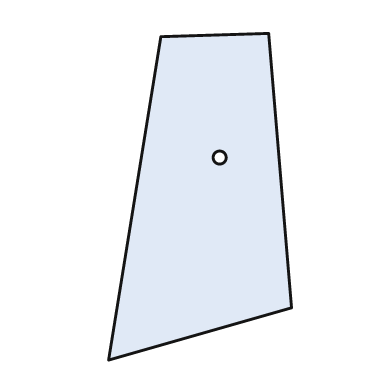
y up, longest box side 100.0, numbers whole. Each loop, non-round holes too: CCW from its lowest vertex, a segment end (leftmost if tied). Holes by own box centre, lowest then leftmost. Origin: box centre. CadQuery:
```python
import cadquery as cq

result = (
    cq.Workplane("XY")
    .moveTo(-28.0, -50.0)
    .lineTo(28.0, -34.0)
    .lineTo(21.0, 50.0)
    .lineTo(-12.0, 49.0)
    .close()
    .moveTo(6.0, 12.0)
    .circle(2.0)
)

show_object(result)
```